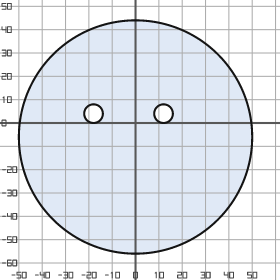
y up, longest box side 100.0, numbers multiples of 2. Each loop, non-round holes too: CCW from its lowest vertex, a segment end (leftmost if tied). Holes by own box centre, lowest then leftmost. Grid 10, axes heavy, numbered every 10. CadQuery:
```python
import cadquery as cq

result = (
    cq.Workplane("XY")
    .moveTo(0.0, -6.0)
    .circle(50.0)
    .moveTo(-18.0, 4.0)
    .circle(4.0)
    .moveTo(12.0, 4.0)
    .circle(4.0)
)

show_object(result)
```